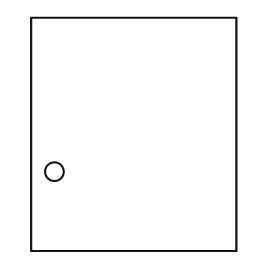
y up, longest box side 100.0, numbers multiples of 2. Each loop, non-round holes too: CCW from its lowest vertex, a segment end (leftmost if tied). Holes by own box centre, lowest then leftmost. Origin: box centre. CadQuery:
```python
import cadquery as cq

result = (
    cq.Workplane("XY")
    .moveTo(-44.0, -50.0)
    .lineTo(44.0, -50.0)
    .lineTo(44.0, 50.0)
    .lineTo(-44.0, 50.0)
    .close()
    .moveTo(-34.0, -16.0)
    .circle(4.0)
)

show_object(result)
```